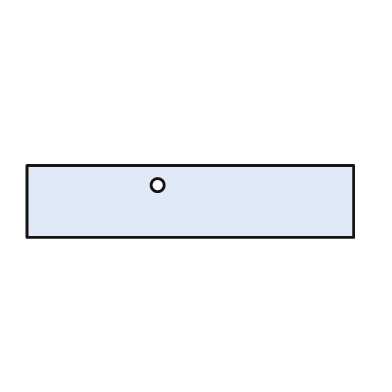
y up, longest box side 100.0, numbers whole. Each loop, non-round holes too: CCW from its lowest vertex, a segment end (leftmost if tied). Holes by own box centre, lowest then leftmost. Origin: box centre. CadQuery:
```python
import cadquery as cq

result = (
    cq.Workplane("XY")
    .moveTo(-50.0, -11.0)
    .lineTo(50.0, -11.0)
    .lineTo(50.0, 11.0)
    .lineTo(-50.0, 11.0)
    .close()
    .moveTo(-10.0, 5.0)
    .circle(2.0)
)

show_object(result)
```